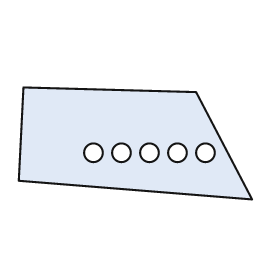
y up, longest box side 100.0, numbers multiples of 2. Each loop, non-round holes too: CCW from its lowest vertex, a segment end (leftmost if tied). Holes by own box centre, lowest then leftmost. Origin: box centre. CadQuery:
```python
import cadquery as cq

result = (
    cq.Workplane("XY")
    .moveTo(50.0, -24.0)
    .lineTo(26.0, 22.0)
    .lineTo(-48.0, 24.0)
    .lineTo(-50.0, -16.0)
    .close()
    .moveTo(-18.0, -4.0)
    .circle(4.0)
    .moveTo(-6.0, -4.0)
    .circle(4.0)
    .moveTo(6.0, -4.0)
    .circle(4.0)
    .moveTo(18.0, -4.0)
    .circle(4.0)
    .moveTo(30.0, -4.0)
    .circle(4.0)
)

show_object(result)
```